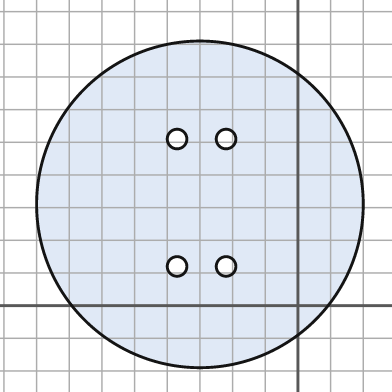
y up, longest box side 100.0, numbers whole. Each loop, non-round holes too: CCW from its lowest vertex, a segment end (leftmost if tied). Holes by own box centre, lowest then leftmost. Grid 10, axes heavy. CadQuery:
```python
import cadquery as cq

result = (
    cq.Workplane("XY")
    .moveTo(-30.0, 31.0)
    .circle(50.0)
    .moveTo(-37.0, 12.0)
    .circle(3.0)
    .moveTo(-22.0, 12.0)
    .circle(3.0)
    .moveTo(-37.0, 51.0)
    .circle(3.0)
    .moveTo(-22.0, 51.0)
    .circle(3.0)
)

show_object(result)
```